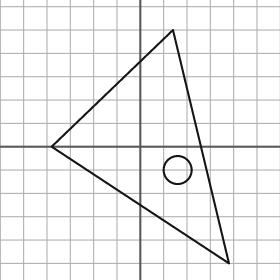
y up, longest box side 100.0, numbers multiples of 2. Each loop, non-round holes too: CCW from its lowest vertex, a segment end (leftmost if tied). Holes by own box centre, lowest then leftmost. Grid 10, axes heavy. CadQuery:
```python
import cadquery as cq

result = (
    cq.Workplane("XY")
    .moveTo(38.0, -50.0)
    .lineTo(14.0, 50.0)
    .lineTo(-38.0, 0.0)
    .close()
    .moveTo(16.0, -10.0)
    .circle(6.0)
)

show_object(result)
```